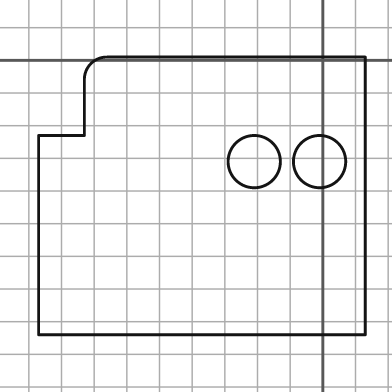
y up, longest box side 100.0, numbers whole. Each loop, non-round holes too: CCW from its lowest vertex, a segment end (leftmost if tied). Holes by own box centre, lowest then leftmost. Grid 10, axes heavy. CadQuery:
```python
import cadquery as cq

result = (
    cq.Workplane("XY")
    .moveTo(-87.0, -84.0)
    .lineTo(13.0, -84.0)
    .lineTo(13.0, 1.0)
    .lineTo(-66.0, 1.0)
    .threePointArc((-71.0, -1.0), (-73.0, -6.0))
    .lineTo(-73.0, -23.0)
    .lineTo(-87.0, -23.0)
    .close()
    .moveTo(-21.0, -31.0)
    .circle(8.0)
    .moveTo(-1.0, -31.0)
    .circle(8.0)
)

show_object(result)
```